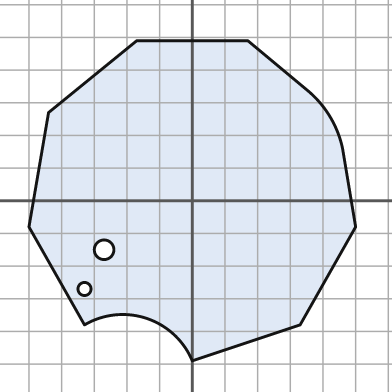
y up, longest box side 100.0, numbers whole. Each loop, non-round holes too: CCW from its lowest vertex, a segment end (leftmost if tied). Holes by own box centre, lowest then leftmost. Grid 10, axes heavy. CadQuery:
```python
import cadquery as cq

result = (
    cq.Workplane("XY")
    .moveTo(0.0, -49.0)
    .lineTo(33.0, -38.0)
    .lineTo(50.0, -8.0)
    .lineTo(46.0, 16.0)
    .threePointArc((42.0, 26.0), (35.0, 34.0))
    .lineTo(17.0, 49.0)
    .lineTo(-17.0, 49.0)
    .lineTo(-44.0, 27.0)
    .lineTo(-50.0, -8.0)
    .lineTo(-33.0, -38.0)
    .threePointArc((-14.0, -36.0), (0.0, -49.0))
    .close()
    .moveTo(-33.0, -27.0)
    .circle(2.0)
    .moveTo(-27.0, -15.0)
    .circle(3.0)
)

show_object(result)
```